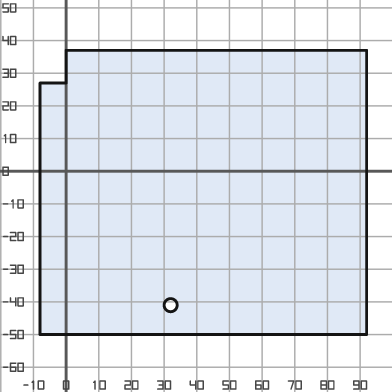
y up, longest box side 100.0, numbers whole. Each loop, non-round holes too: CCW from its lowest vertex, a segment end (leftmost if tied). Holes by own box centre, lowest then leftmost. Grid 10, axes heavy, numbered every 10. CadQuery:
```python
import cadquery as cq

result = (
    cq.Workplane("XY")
    .moveTo(-8.0, -50.0)
    .lineTo(92.0, -50.0)
    .lineTo(92.0, 37.0)
    .lineTo(0.0, 37.0)
    .lineTo(0.0, 27.0)
    .lineTo(-8.0, 27.0)
    .close()
    .moveTo(32.0, -41.0)
    .circle(2.0)
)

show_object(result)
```